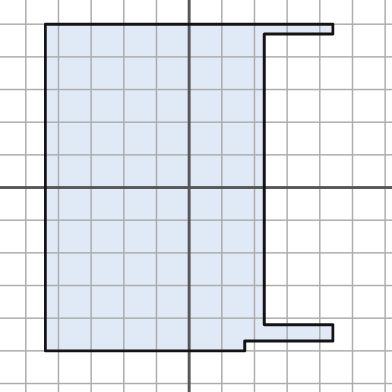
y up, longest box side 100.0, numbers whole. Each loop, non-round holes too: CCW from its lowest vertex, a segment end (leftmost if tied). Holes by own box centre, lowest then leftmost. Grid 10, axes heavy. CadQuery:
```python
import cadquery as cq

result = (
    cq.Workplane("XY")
    .moveTo(-44.0, -50.0)
    .lineTo(17.0, -50.0)
    .lineTo(17.0, -47.0)
    .lineTo(44.0, -47.0)
    .lineTo(44.0, -42.0)
    .lineTo(23.0, -42.0)
    .lineTo(23.0, 47.0)
    .lineTo(44.0, 47.0)
    .lineTo(44.0, 50.0)
    .lineTo(-44.0, 50.0)
    .close()
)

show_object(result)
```